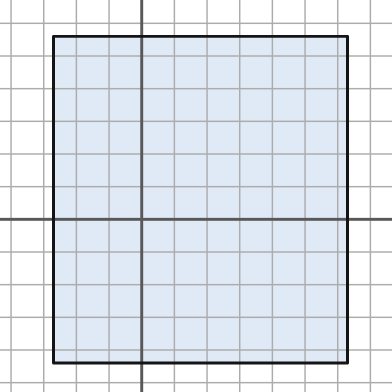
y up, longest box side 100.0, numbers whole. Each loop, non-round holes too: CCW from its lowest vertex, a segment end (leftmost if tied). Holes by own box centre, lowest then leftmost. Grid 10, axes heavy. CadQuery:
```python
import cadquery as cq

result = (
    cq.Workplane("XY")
    .moveTo(-27.0, -44.0)
    .lineTo(63.0, -44.0)
    .lineTo(63.0, 56.0)
    .lineTo(-27.0, 56.0)
    .close()
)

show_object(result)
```